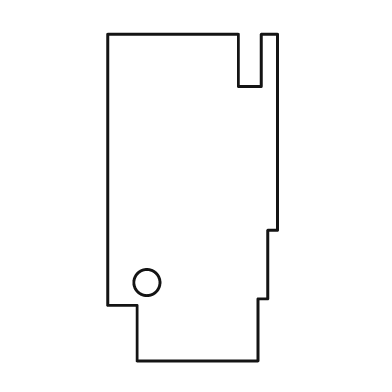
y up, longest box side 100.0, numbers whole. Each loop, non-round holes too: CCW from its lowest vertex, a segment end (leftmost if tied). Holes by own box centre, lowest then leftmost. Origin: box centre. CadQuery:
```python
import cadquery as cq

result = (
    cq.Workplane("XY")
    .moveTo(-17.0, -50.0)
    .lineTo(20.0, -50.0)
    .lineTo(20.0, -31.0)
    .lineTo(23.0, -31.0)
    .lineTo(23.0, -10.0)
    .lineTo(26.0, -10.0)
    .lineTo(26.0, 50.0)
    .lineTo(21.0, 50.0)
    .lineTo(21.0, 34.0)
    .lineTo(14.0, 34.0)
    .lineTo(14.0, 50.0)
    .lineTo(-26.0, 50.0)
    .lineTo(-26.0, -33.0)
    .lineTo(-17.0, -33.0)
    .close()
    .moveTo(-14.0, -26.0)
    .circle(4.0)
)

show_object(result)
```